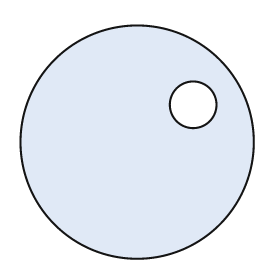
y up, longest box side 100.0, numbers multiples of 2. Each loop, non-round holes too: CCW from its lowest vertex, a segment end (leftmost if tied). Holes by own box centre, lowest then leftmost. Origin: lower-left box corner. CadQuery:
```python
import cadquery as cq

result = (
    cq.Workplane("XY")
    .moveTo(50.0, 50.0)
    .circle(50.0)
    .moveTo(74.0, 66.0)
    .circle(10.0)
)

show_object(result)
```